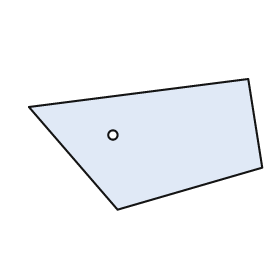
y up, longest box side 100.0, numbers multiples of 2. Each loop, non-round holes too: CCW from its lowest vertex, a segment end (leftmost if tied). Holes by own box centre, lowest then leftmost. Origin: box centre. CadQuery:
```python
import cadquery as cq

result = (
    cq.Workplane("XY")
    .moveTo(-12.0, -28.0)
    .lineTo(50.0, -10.0)
    .lineTo(44.0, 28.0)
    .lineTo(-50.0, 16.0)
    .close()
    .moveTo(-14.0, 4.0)
    .circle(2.0)
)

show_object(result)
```